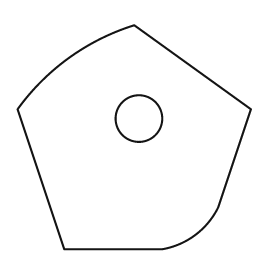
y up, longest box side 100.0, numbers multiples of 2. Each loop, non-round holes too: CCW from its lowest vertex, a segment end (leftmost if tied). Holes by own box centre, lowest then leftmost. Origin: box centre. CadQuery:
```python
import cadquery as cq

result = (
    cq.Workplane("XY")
    .moveTo(-30.0, -48.0)
    .lineTo(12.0, -48.0)
    .threePointArc((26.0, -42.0), (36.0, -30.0))
    .lineTo(50.0, 12.0)
    .lineTo(0.0, 48.0)
    .threePointArc((-28.0, 34.0), (-50.0, 12.0))
    .close()
    .moveTo(2.0, 8.0)
    .circle(10.0)
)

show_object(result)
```